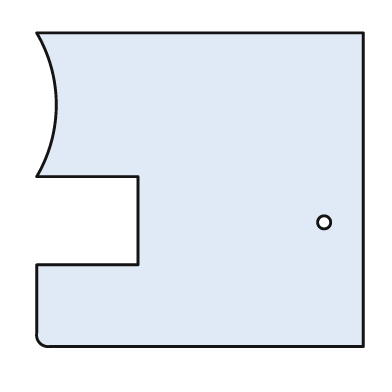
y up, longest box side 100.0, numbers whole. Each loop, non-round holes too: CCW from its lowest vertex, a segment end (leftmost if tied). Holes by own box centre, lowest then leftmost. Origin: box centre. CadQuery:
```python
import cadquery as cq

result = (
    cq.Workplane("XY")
    .moveTo(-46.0, -48.0)
    .lineTo(50.0, -48.0)
    .lineTo(50.0, 48.0)
    .lineTo(-50.0, 48.0)
    .threePointArc((-44.0, 26.0), (-50.0, 4.0))
    .lineTo(-19.0, 4.0)
    .lineTo(-19.0, -23.0)
    .lineTo(-50.0, -23.0)
    .lineTo(-50.0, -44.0)
    .threePointArc((-49.0, -47.0), (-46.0, -48.0))
    .close()
    .moveTo(38.0, -10.0)
    .circle(2.0)
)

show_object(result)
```